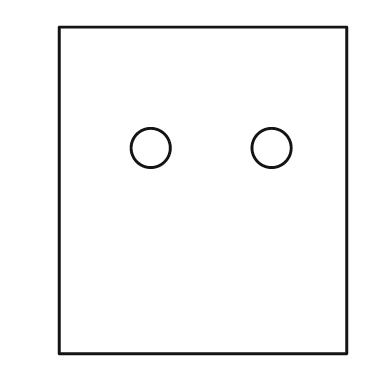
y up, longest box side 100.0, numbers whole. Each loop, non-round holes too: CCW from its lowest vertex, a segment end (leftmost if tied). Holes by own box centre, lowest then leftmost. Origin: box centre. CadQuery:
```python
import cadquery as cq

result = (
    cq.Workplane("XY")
    .moveTo(-44.0, -50.0)
    .lineTo(44.0, -50.0)
    .lineTo(44.0, 50.0)
    .lineTo(-44.0, 50.0)
    .close()
    .moveTo(-16.0, 13.0)
    .circle(6.0)
    .moveTo(21.0, 13.0)
    .circle(6.0)
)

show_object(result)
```